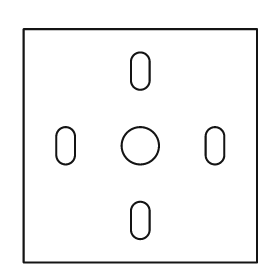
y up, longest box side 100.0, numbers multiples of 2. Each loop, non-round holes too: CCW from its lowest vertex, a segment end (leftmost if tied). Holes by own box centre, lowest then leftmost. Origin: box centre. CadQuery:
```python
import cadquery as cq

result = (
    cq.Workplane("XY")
    .moveTo(-50.0, -50.0)
    .lineTo(50.0, -50.0)
    .lineTo(50.0, 50.0)
    .lineTo(-50.0, 50.0)
    .close()
    .moveTo(-4.0, -36.0)
    .threePointArc((0.0, -40.0), (4.0, -36.0))
    .lineTo(4.0, -28.0)
    .threePointArc((0.0, -24.0), (-4.0, -28.0))
    .close()
    .moveTo(-36.0, -4.0)
    .threePointArc((-32.0, -8.0), (-28.0, -4.0))
    .lineTo(-28.0, 4.0)
    .threePointArc((-32.0, 8.0), (-36.0, 4.0))
    .close()
    .moveTo(0.0, 0.0)
    .circle(8.0)
    .moveTo(28.0, -4.0)
    .threePointArc((32.0, -8.0), (36.0, -4.0))
    .lineTo(36.0, 4.0)
    .threePointArc((32.0, 8.0), (28.0, 4.0))
    .close()
    .moveTo(-4.0, 28.0)
    .threePointArc((0.0, 24.0), (4.0, 28.0))
    .lineTo(4.0, 36.0)
    .threePointArc((0.0, 40.0), (-4.0, 36.0))
    .close()
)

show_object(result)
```